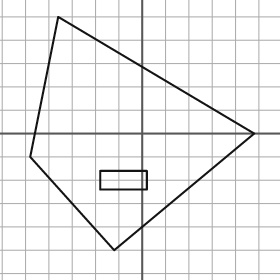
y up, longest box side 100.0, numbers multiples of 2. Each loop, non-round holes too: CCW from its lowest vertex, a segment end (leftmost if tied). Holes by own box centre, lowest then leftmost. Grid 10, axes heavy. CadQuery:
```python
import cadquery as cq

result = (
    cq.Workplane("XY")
    .moveTo(-12.0, -50.0)
    .lineTo(48.0, 0.0)
    .lineTo(-36.0, 50.0)
    .lineTo(-48.0, -10.0)
    .close()
    .moveTo(-18.0, -24.0)
    .lineTo(2.0, -24.0)
    .lineTo(2.0, -16.0)
    .lineTo(-18.0, -16.0)
    .close()
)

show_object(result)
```